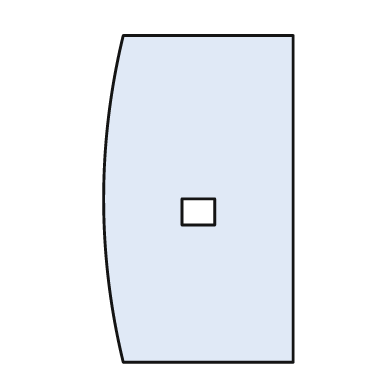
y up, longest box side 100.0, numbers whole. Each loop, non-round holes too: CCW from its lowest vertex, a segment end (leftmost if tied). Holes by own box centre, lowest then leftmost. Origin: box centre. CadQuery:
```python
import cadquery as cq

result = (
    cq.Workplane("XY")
    .moveTo(-23.0, -50.0)
    .lineTo(29.0, -50.0)
    .lineTo(29.0, 50.0)
    .lineTo(-23.0, 50.0)
    .threePointArc((-29.0, 0.0), (-23.0, -50.0))
    .close()
    .moveTo(-5.0, -8.0)
    .lineTo(5.0, -8.0)
    .lineTo(5.0, 0.0)
    .lineTo(-5.0, 0.0)
    .close()
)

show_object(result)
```